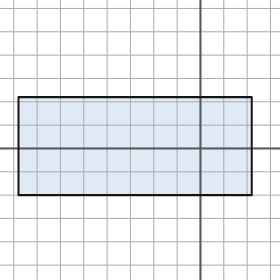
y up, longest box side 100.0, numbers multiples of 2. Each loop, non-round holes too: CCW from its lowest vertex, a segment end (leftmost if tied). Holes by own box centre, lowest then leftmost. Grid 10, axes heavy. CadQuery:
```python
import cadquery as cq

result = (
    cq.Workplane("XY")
    .moveTo(-78.0, -20.0)
    .lineTo(22.0, -20.0)
    .lineTo(22.0, 22.0)
    .lineTo(-78.0, 22.0)
    .close()
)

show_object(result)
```